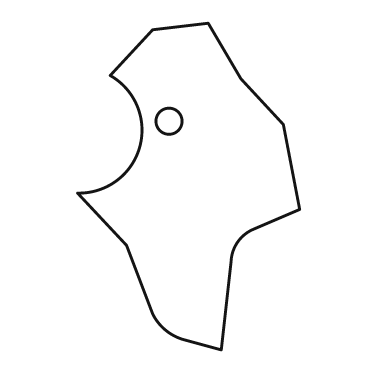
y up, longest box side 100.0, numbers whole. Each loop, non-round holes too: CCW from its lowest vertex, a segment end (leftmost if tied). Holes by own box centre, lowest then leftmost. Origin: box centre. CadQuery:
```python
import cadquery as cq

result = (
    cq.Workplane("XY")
    .moveTo(10.0, -50.0)
    .lineTo(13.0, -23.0)
    .threePointArc((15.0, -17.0), (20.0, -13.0))
    .lineTo(34.0, -7.0)
    .lineTo(29.0, 19.0)
    .lineTo(16.0, 33.0)
    .lineTo(6.0, 50.0)
    .lineTo(-11.0, 48.0)
    .lineTo(-24.0, 34.0)
    .threePointArc((-15.0, 12.0), (-34.0, -2.0))
    .lineTo(-19.0, -18.0)
    .lineTo(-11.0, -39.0)
    .threePointArc((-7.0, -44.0), (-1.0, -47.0))
    .close()
    .moveTo(-6.0, 20.0)
    .circle(4.0)
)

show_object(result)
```